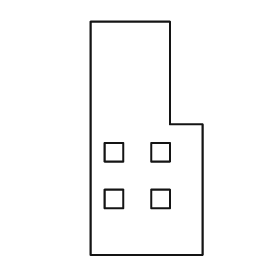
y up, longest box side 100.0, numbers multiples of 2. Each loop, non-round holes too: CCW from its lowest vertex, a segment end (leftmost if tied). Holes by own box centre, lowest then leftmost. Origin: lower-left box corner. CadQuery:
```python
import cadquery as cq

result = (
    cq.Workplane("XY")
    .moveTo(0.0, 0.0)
    .lineTo(48.0, 0.0)
    .lineTo(48.0, 56.0)
    .lineTo(34.0, 56.0)
    .lineTo(34.0, 100.0)
    .lineTo(0.0, 100.0)
    .close()
    .moveTo(6.0, 20.0)
    .lineTo(14.0, 20.0)
    .lineTo(14.0, 28.0)
    .lineTo(6.0, 28.0)
    .close()
    .moveTo(26.0, 20.0)
    .lineTo(34.0, 20.0)
    .lineTo(34.0, 28.0)
    .lineTo(26.0, 28.0)
    .close()
    .moveTo(6.0, 40.0)
    .lineTo(14.0, 40.0)
    .lineTo(14.0, 48.0)
    .lineTo(6.0, 48.0)
    .close()
    .moveTo(26.0, 40.0)
    .lineTo(34.0, 40.0)
    .lineTo(34.0, 48.0)
    .lineTo(26.0, 48.0)
    .close()
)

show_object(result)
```